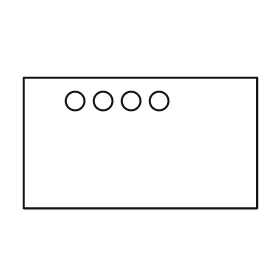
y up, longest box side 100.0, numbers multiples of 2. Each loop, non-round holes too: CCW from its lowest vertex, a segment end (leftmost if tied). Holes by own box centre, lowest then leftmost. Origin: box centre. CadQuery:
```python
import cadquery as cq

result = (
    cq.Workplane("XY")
    .moveTo(-50.0, -28.0)
    .lineTo(50.0, -28.0)
    .lineTo(50.0, 28.0)
    .lineTo(-50.0, 28.0)
    .close()
    .moveTo(-28.0, 18.0)
    .circle(4.0)
    .moveTo(-16.0, 18.0)
    .circle(4.0)
    .moveTo(-4.0, 18.0)
    .circle(4.0)
    .moveTo(8.0, 18.0)
    .circle(4.0)
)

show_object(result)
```